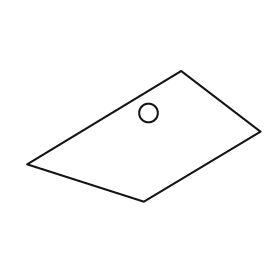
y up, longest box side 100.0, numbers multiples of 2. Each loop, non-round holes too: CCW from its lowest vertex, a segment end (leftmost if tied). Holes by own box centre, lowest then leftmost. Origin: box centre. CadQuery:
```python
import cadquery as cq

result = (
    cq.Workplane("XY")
    .moveTo(0.0, -28.0)
    .lineTo(50.0, 2.0)
    .lineTo(16.0, 28.0)
    .lineTo(-50.0, -12.0)
    .close()
    .moveTo(2.0, 10.0)
    .circle(4.0)
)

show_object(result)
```